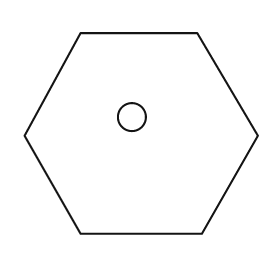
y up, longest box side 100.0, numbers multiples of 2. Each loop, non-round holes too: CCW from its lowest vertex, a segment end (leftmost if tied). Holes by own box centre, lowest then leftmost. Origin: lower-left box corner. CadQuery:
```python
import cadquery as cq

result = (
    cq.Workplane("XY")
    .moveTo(24.0, 0.0)
    .lineTo(76.0, 0.0)
    .lineTo(100.0, 42.0)
    .lineTo(74.0, 86.0)
    .lineTo(24.0, 86.0)
    .lineTo(0.0, 42.0)
    .close()
    .moveTo(46.0, 50.0)
    .circle(6.0)
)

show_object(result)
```